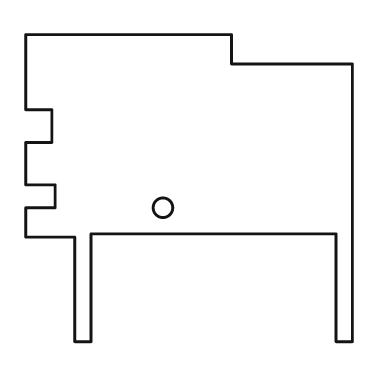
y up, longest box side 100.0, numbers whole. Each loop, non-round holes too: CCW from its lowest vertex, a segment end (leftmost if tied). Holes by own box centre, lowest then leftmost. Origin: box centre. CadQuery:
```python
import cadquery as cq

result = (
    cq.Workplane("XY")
    .moveTo(-35.0, -47.0)
    .lineTo(-30.0, -47.0)
    .lineTo(-30.0, -14.0)
    .lineTo(45.0, -14.0)
    .lineTo(45.0, -47.0)
    .lineTo(50.0, -47.0)
    .lineTo(50.0, 38.0)
    .lineTo(13.0, 38.0)
    .lineTo(13.0, 47.0)
    .lineTo(-50.0, 47.0)
    .lineTo(-50.0, 24.0)
    .lineTo(-42.0, 24.0)
    .lineTo(-42.0, 14.0)
    .lineTo(-50.0, 14.0)
    .lineTo(-50.0, 1.0)
    .lineTo(-41.0, 1.0)
    .lineTo(-41.0, -6.0)
    .lineTo(-50.0, -6.0)
    .lineTo(-50.0, -15.0)
    .lineTo(-35.0, -15.0)
    .close()
    .moveTo(-8.0, -6.0)
    .circle(3.0)
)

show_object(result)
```